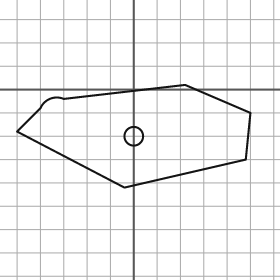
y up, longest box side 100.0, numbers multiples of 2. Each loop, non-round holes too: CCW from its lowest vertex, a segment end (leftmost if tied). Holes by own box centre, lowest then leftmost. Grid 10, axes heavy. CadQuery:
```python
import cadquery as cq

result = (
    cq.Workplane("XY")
    .moveTo(-4.0, -42.0)
    .lineTo(48.0, -30.0)
    .lineTo(50.0, -10.0)
    .lineTo(22.0, 2.0)
    .lineTo(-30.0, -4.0)
    .threePointArc((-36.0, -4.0), (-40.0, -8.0))
    .lineTo(-50.0, -18.0)
    .close()
    .moveTo(0.0, -20.0)
    .circle(4.0)
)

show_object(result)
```